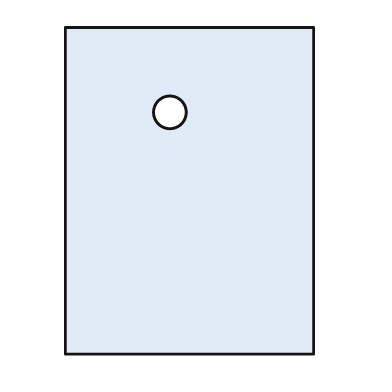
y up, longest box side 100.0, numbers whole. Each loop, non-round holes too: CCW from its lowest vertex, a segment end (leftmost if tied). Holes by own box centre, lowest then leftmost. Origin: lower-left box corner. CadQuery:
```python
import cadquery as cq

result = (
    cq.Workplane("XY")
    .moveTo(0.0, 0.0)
    .lineTo(76.0, 0.0)
    .lineTo(76.0, 100.0)
    .lineTo(0.0, 100.0)
    .close()
    .moveTo(32.0, 74.0)
    .circle(5.0)
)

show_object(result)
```